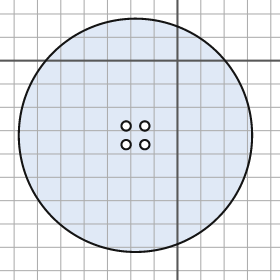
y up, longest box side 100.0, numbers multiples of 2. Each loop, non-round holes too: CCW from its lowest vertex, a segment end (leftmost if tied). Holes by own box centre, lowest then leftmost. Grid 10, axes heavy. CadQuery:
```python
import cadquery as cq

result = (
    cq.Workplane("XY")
    .moveTo(-18.0, -32.0)
    .circle(50.0)
    .moveTo(-22.0, -36.0)
    .circle(2.0)
    .moveTo(-14.0, -36.0)
    .circle(2.0)
    .moveTo(-22.0, -28.0)
    .circle(2.0)
    .moveTo(-14.0, -28.0)
    .circle(2.0)
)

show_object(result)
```